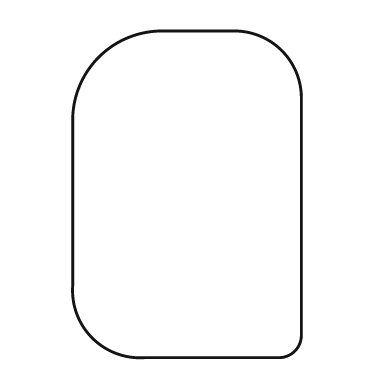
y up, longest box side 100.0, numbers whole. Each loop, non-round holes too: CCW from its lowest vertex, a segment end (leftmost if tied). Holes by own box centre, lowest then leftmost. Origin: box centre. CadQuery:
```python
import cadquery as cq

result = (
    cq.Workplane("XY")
    .moveTo(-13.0, -50.0)
    .lineTo(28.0, -50.0)
    .threePointArc((33.0, -48.0), (35.0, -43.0))
    .lineTo(35.0, 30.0)
    .threePointArc((29.0, 44.0), (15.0, 50.0))
    .lineTo(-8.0, 50.0)
    .threePointArc((-27.0, 42.0), (-35.0, 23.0))
    .lineTo(-35.0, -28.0)
    .threePointArc((-29.0, -44.0), (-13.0, -50.0))
    .close()
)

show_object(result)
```